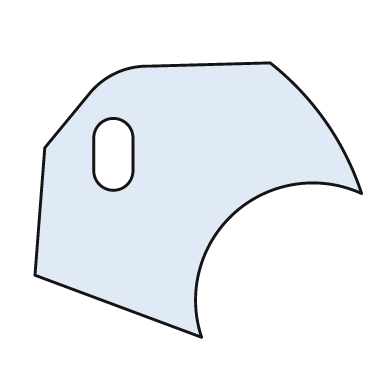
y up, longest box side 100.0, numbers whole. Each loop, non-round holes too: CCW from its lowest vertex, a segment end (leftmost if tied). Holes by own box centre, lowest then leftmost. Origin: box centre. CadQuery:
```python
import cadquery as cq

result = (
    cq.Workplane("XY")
    .moveTo(1.0, -42.0)
    .threePointArc((11.0, -4.0), (50.0, 2.0))
    .threePointArc((39.0, 24.0), (22.0, 42.0))
    .lineTo(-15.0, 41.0)
    .threePointArc((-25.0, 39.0), (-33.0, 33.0))
    .lineTo(-47.0, 16.0)
    .lineTo(-50.0, -23.0)
    .close()
    .moveTo(-32.0, 9.0)
    .threePointArc((-26.0, 3.0), (-20.0, 9.0))
    .lineTo(-20.0, 19.0)
    .threePointArc((-26.0, 25.0), (-32.0, 19.0))
    .close()
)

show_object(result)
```